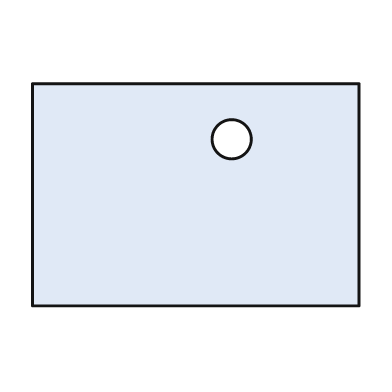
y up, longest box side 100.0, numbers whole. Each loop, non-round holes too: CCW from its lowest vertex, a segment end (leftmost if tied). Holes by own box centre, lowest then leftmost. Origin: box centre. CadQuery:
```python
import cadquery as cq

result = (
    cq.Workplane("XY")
    .moveTo(-50.0, -34.0)
    .lineTo(50.0, -34.0)
    .lineTo(50.0, 34.0)
    .lineTo(-50.0, 34.0)
    .close()
    .moveTo(11.0, 17.0)
    .circle(6.0)
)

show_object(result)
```